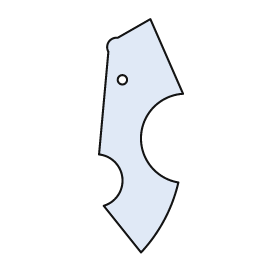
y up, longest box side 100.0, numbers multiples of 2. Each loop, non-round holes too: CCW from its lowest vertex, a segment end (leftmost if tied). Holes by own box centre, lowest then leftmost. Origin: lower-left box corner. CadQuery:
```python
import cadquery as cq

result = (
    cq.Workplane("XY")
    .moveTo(18.0, 0.0)
    .threePointArc((28.0, 14.0), (34.0, 30.0))
    .threePointArc((18.0, 50.0), (36.0, 68.0))
    .lineTo(22.0, 100.0)
    .lineTo(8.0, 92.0)
    .threePointArc((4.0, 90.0), (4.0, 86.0))
    .lineTo(0.0, 42.0)
    .threePointArc((10.0, 32.0), (2.0, 20.0))
    .close()
    .moveTo(10.0, 74.0)
    .circle(2.0)
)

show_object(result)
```